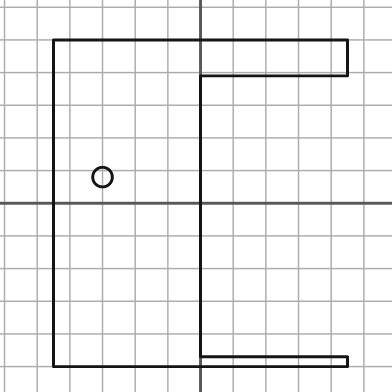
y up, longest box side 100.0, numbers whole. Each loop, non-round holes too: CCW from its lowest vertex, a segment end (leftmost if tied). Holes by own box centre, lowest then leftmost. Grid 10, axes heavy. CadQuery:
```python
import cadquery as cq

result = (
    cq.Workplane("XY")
    .moveTo(-45.0, -50.0)
    .lineTo(45.0, -50.0)
    .lineTo(45.0, -47.0)
    .lineTo(0.0, -47.0)
    .lineTo(0.0, 39.0)
    .lineTo(45.0, 39.0)
    .lineTo(45.0, 50.0)
    .lineTo(-45.0, 50.0)
    .close()
    .moveTo(-30.0, 8.0)
    .circle(3.0)
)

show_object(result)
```